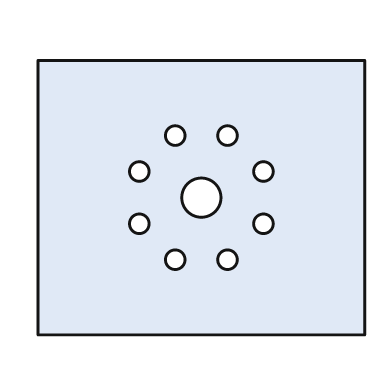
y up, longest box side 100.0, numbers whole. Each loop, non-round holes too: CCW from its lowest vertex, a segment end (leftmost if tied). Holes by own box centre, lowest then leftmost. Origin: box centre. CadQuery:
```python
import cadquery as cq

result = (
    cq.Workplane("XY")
    .moveTo(-50.0, -42.0)
    .lineTo(50.0, -42.0)
    .lineTo(50.0, 42.0)
    .lineTo(-50.0, 42.0)
    .close()
    .moveTo(-8.0, -19.0)
    .circle(3.0)
    .moveTo(8.0, -19.0)
    .circle(3.0)
    .moveTo(-19.0, -8.0)
    .circle(3.0)
    .moveTo(19.0, -8.0)
    .circle(3.0)
    .moveTo(0.0, 0.0)
    .circle(6.0)
    .moveTo(-19.0, 8.0)
    .circle(3.0)
    .moveTo(19.0, 8.0)
    .circle(3.0)
    .moveTo(-8.0, 19.0)
    .circle(3.0)
    .moveTo(8.0, 19.0)
    .circle(3.0)
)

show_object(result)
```